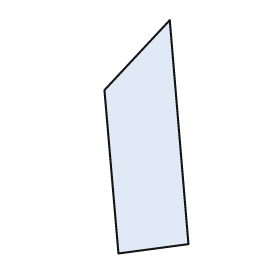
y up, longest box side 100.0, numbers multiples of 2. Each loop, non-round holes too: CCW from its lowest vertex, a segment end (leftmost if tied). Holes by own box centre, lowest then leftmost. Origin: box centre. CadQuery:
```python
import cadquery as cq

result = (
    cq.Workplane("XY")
    .moveTo(-12.0, -50.0)
    .lineTo(18.0, -46.0)
    .lineTo(10.0, 50.0)
    .lineTo(-18.0, 20.0)
    .close()
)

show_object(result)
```